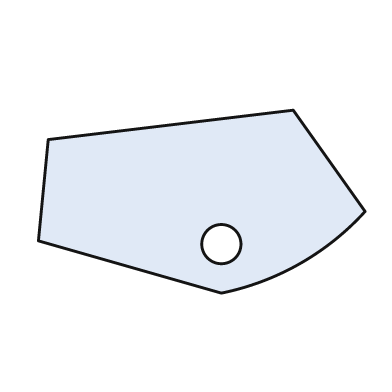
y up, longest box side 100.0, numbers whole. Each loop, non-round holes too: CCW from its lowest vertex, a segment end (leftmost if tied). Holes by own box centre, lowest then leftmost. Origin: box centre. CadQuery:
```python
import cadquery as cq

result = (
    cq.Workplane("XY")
    .moveTo(6.0, -28.0)
    .threePointArc((30.0, -19.0), (50.0, -3.0))
    .lineTo(28.0, 28.0)
    .lineTo(-47.0, 19.0)
    .lineTo(-50.0, -12.0)
    .close()
    .moveTo(6.0, -13.0)
    .circle(6.0)
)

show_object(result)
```